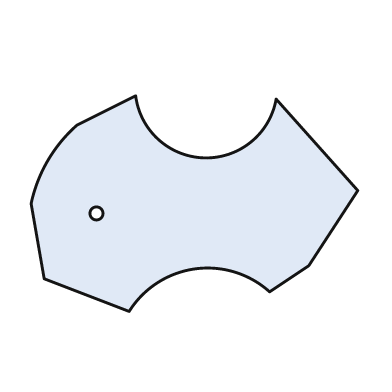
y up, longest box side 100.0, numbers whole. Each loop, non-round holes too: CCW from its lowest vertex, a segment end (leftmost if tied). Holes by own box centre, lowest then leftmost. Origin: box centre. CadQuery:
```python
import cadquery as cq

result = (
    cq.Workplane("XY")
    .moveTo(-20.0, -33.0)
    .threePointArc((0.0, -20.0), (23.0, -27.0))
    .lineTo(35.0, -19.0)
    .lineTo(50.0, 4.0)
    .lineTo(25.0, 32.0)
    .threePointArc((3.0, 14.0), (-18.0, 33.0))
    .lineTo(-36.0, 24.0)
    .threePointArc((-45.0, 13.0), (-50.0, 0.0))
    .lineTo(-46.0, -23.0)
    .close()
    .moveTo(-30.0, -3.0)
    .circle(2.0)
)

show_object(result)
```